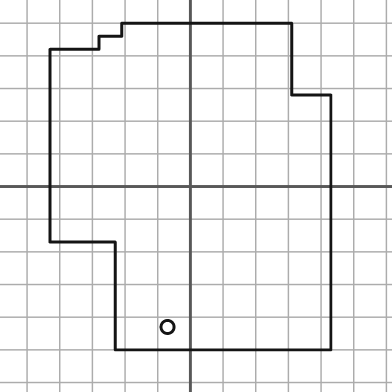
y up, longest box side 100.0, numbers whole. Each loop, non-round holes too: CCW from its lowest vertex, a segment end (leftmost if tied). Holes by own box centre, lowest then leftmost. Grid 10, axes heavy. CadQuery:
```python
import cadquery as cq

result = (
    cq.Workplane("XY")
    .moveTo(-23.0, -50.0)
    .lineTo(43.0, -50.0)
    .lineTo(43.0, 28.0)
    .lineTo(31.0, 28.0)
    .lineTo(31.0, 50.0)
    .lineTo(-21.0, 50.0)
    .lineTo(-21.0, 46.0)
    .lineTo(-28.0, 46.0)
    .lineTo(-28.0, 42.0)
    .lineTo(-43.0, 42.0)
    .lineTo(-43.0, -17.0)
    .lineTo(-23.0, -17.0)
    .close()
    .moveTo(-7.0, -43.0)
    .circle(2.0)
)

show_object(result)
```